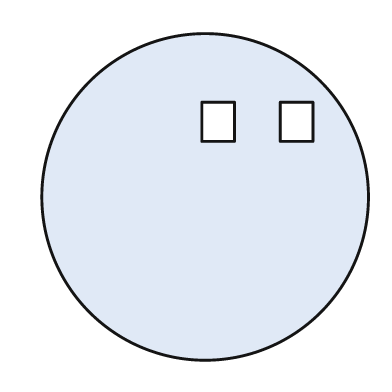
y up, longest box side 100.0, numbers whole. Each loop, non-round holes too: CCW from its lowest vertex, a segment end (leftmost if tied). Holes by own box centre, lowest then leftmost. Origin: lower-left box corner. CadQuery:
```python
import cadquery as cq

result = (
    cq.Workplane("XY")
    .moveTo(50.0, 50.0)
    .circle(50.0)
    .moveTo(49.0, 67.0)
    .lineTo(59.0, 67.0)
    .lineTo(59.0, 79.0)
    .lineTo(49.0, 79.0)
    .close()
    .moveTo(73.0, 67.0)
    .lineTo(83.0, 67.0)
    .lineTo(83.0, 79.0)
    .lineTo(73.0, 79.0)
    .close()
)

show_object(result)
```